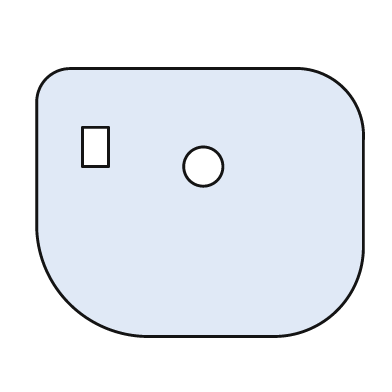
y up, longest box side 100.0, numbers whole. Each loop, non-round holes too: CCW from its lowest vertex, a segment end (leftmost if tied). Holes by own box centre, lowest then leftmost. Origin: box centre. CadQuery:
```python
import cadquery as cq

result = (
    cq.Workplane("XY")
    .moveTo(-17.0, -41.0)
    .lineTo(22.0, -41.0)
    .threePointArc((42.0, -33.0), (50.0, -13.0))
    .lineTo(50.0, 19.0)
    .threePointArc((44.0, 35.0), (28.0, 41.0))
    .lineTo(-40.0, 41.0)
    .threePointArc((-47.0, 38.0), (-50.0, 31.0))
    .lineTo(-50.0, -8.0)
    .threePointArc((-40.0, -31.0), (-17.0, -41.0))
    .close()
    .moveTo(1.0, 11.0)
    .circle(6.0)
    .moveTo(-36.0, 11.0)
    .lineTo(-28.0, 11.0)
    .lineTo(-28.0, 23.0)
    .lineTo(-36.0, 23.0)
    .close()
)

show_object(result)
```